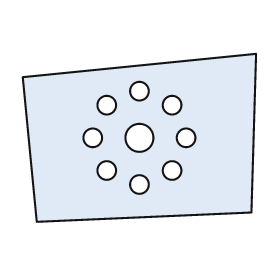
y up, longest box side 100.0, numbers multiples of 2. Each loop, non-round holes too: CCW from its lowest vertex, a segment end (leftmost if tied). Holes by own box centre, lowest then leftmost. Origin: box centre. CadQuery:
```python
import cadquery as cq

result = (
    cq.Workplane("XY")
    .moveTo(-44.0, -36.0)
    .lineTo(48.0, -32.0)
    .lineTo(50.0, 36.0)
    .lineTo(-50.0, 26.0)
    .close()
    .moveTo(0.0, -20.0)
    .circle(4.0)
    .moveTo(-14.0, -14.0)
    .circle(4.0)
    .moveTo(14.0, -14.0)
    .circle(4.0)
    .moveTo(-20.0, 0.0)
    .circle(4.0)
    .moveTo(0.0, 0.0)
    .circle(6.0)
    .moveTo(20.0, 0.0)
    .circle(4.0)
    .moveTo(-14.0, 14.0)
    .circle(4.0)
    .moveTo(14.0, 14.0)
    .circle(4.0)
    .moveTo(0.0, 20.0)
    .circle(4.0)
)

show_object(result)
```